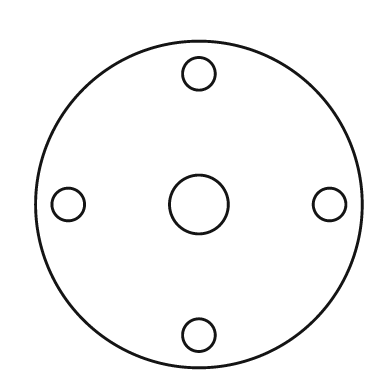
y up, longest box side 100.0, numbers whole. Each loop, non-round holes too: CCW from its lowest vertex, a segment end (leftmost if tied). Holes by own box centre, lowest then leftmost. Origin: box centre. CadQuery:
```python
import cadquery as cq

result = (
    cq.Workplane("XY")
    .moveTo(0.0, 0.0)
    .circle(50.0)
    .moveTo(0.0, -40.0)
    .circle(5.0)
    .moveTo(-40.0, 0.0)
    .circle(5.0)
    .moveTo(0.0, 0.0)
    .circle(9.0)
    .moveTo(40.0, 0.0)
    .circle(5.0)
    .moveTo(0.0, 40.0)
    .circle(5.0)
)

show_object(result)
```